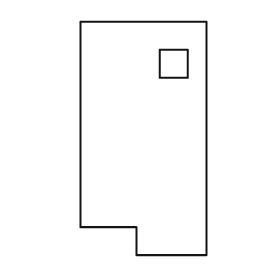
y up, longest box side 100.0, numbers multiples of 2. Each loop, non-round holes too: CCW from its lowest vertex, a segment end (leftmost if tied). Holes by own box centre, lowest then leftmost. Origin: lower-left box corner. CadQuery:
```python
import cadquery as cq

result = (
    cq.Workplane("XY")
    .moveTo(24.0, 0.0)
    .lineTo(54.0, 0.0)
    .lineTo(54.0, 100.0)
    .lineTo(0.0, 100.0)
    .lineTo(0.0, 12.0)
    .lineTo(24.0, 12.0)
    .close()
    .moveTo(34.0, 76.0)
    .lineTo(46.0, 76.0)
    .lineTo(46.0, 88.0)
    .lineTo(34.0, 88.0)
    .close()
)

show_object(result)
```